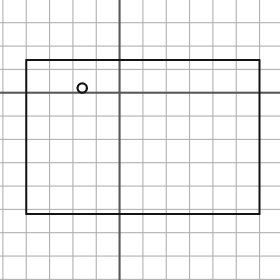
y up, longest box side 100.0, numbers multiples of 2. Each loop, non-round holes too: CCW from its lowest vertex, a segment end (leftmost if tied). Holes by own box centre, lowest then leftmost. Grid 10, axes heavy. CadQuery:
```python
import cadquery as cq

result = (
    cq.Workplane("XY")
    .moveTo(-40.0, -52.0)
    .lineTo(60.0, -52.0)
    .lineTo(60.0, 14.0)
    .lineTo(-40.0, 14.0)
    .close()
    .moveTo(-16.0, 2.0)
    .circle(2.0)
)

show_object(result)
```